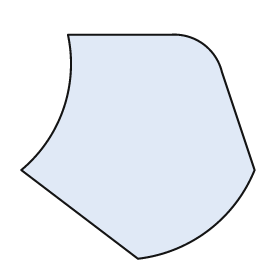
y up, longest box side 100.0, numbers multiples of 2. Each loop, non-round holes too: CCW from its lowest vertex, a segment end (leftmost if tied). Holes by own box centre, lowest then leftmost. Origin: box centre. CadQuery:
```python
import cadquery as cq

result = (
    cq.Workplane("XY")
    .moveTo(0.0, -48.0)
    .threePointArc((30.0, -36.0), (50.0, -10.0))
    .lineTo(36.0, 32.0)
    .threePointArc((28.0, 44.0), (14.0, 48.0))
    .lineTo(-30.0, 48.0)
    .threePointArc((-32.0, 16.0), (-50.0, -10.0))
    .close()
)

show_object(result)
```